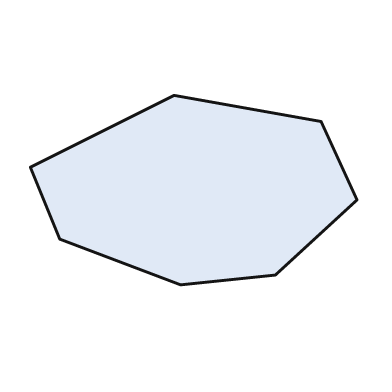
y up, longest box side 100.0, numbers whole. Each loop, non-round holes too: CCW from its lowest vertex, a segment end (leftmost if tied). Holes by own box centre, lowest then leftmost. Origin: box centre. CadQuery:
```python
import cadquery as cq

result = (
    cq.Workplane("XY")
    .moveTo(-4.0, -29.0)
    .lineTo(25.0, -26.0)
    .lineTo(50.0, -3.0)
    .lineTo(39.0, 21.0)
    .lineTo(-6.0, 29.0)
    .lineTo(-50.0, 7.0)
    .lineTo(-41.0, -15.0)
    .close()
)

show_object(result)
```